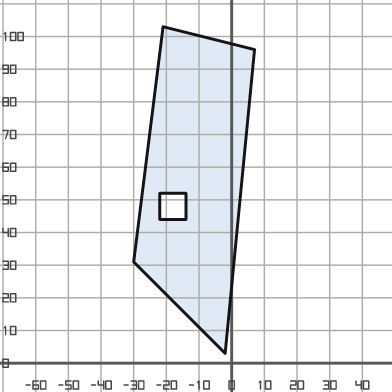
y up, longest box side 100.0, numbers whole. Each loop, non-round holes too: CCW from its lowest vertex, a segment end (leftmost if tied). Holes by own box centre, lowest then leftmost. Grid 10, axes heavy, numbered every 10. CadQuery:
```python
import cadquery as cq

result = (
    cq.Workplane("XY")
    .moveTo(-2.0, 3.0)
    .lineTo(7.0, 96.0)
    .lineTo(-21.0, 103.0)
    .lineTo(-30.0, 31.0)
    .close()
    .moveTo(-22.0, 44.0)
    .lineTo(-14.0, 44.0)
    .lineTo(-14.0, 52.0)
    .lineTo(-22.0, 52.0)
    .close()
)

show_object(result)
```